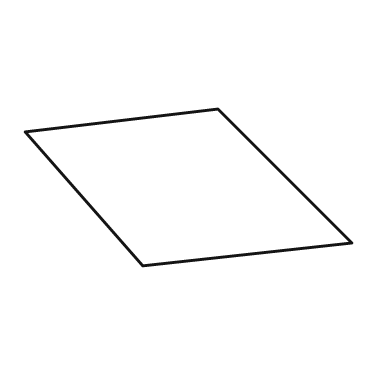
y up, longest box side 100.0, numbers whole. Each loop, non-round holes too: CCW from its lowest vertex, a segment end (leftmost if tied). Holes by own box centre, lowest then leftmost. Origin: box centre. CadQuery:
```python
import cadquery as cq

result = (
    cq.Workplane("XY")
    .moveTo(-14.0, -24.0)
    .lineTo(50.0, -17.0)
    .lineTo(9.0, 24.0)
    .lineTo(-50.0, 17.0)
    .close()
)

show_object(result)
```